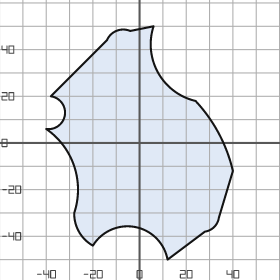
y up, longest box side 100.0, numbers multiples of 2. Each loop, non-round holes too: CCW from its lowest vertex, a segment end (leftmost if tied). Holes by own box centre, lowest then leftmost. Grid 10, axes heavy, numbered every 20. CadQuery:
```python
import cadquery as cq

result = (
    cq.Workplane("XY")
    .moveTo(12.0, -50.0)
    .lineTo(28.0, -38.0)
    .threePointArc((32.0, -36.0), (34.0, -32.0))
    .lineTo(40.0, -12.0)
    .threePointArc((34.0, 4.0), (24.0, 18.0))
    .threePointArc((8.0, 30.0), (6.0, 50.0))
    .lineTo(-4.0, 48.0)
    .threePointArc((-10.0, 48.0), (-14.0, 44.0))
    .lineTo(-38.0, 20.0)
    .threePointArc((-32.0, 12.0), (-40.0, 6.0))
    .threePointArc((-28.0, -10.0), (-28.0, -30.0))
    .threePointArc((-26.0, -38.0), (-20.0, -44.0))
    .threePointArc((-2.0, -36.0), (12.0, -50.0))
    .close()
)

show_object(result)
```